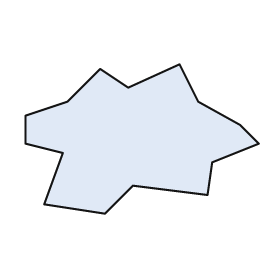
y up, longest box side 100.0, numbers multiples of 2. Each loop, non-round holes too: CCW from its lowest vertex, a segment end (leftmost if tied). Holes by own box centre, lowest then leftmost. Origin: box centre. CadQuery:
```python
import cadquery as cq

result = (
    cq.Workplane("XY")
    .moveTo(-16.0, -32.0)
    .lineTo(-4.0, -20.0)
    .lineTo(28.0, -24.0)
    .lineTo(30.0, -10.0)
    .lineTo(50.0, -2.0)
    .lineTo(42.0, 6.0)
    .lineTo(24.0, 16.0)
    .lineTo(16.0, 32.0)
    .lineTo(-6.0, 22.0)
    .lineTo(-18.0, 30.0)
    .lineTo(-32.0, 16.0)
    .lineTo(-50.0, 10.0)
    .lineTo(-50.0, -2.0)
    .lineTo(-34.0, -6.0)
    .lineTo(-42.0, -28.0)
    .close()
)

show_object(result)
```